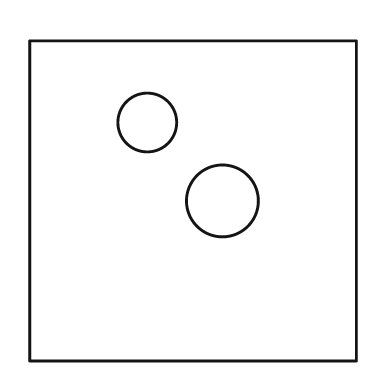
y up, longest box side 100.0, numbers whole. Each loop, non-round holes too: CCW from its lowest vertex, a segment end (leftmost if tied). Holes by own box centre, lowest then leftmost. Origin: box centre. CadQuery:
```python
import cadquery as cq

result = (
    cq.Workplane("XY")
    .moveTo(-50.0, -49.0)
    .lineTo(50.0, -49.0)
    .lineTo(50.0, 49.0)
    .lineTo(-50.0, 49.0)
    .close()
    .moveTo(9.0, 0.0)
    .circle(11.0)
    .moveTo(-14.0, 24.0)
    .circle(9.0)
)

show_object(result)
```